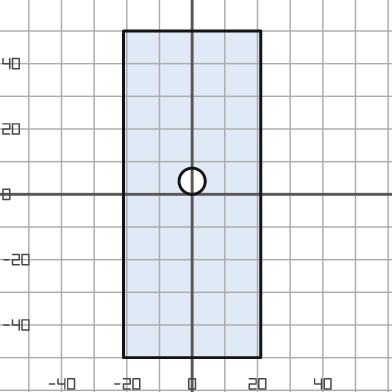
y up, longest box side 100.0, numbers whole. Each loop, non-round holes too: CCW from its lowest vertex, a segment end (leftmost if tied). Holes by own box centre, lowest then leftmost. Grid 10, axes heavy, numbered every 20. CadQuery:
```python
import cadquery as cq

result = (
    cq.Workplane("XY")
    .moveTo(-21.0, -50.0)
    .lineTo(21.0, -50.0)
    .lineTo(21.0, 50.0)
    .lineTo(-21.0, 50.0)
    .close()
    .moveTo(0.0, 4.0)
    .circle(4.0)
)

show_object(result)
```